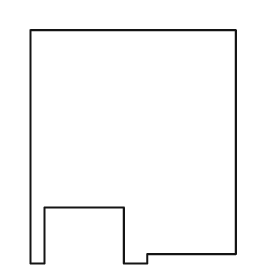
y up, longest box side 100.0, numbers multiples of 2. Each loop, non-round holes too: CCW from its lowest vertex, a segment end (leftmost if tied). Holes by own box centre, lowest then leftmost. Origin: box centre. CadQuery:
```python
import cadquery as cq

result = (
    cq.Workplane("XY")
    .moveTo(-44.0, -50.0)
    .lineTo(-38.0, -50.0)
    .lineTo(-38.0, -26.0)
    .lineTo(-4.0, -26.0)
    .lineTo(-4.0, -50.0)
    .lineTo(6.0, -50.0)
    .lineTo(6.0, -46.0)
    .lineTo(44.0, -46.0)
    .lineTo(44.0, 50.0)
    .lineTo(-44.0, 50.0)
    .close()
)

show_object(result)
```